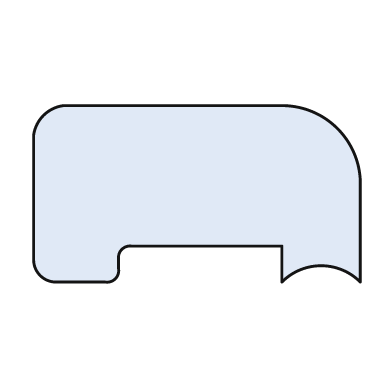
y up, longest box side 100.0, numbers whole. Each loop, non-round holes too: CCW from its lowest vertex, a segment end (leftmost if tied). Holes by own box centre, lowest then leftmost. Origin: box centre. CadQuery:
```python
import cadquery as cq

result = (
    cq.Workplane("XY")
    .moveTo(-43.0, -27.0)
    .lineTo(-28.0, -27.0)
    .threePointArc((-25.0, -26.0), (-24.0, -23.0))
    .lineTo(-24.0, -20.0)
    .threePointArc((-23.0, -17.0), (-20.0, -16.0))
    .lineTo(26.0, -16.0)
    .lineTo(26.0, -27.0)
    .threePointArc((38.0, -22.0), (50.0, -27.0))
    .lineTo(50.0, 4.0)
    .threePointArc((43.0, 20.0), (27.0, 27.0))
    .lineTo(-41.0, 27.0)
    .threePointArc((-47.0, 24.0), (-50.0, 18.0))
    .lineTo(-50.0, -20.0)
    .threePointArc((-48.0, -25.0), (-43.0, -27.0))
    .close()
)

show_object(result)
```